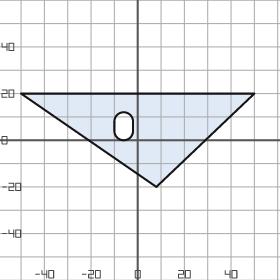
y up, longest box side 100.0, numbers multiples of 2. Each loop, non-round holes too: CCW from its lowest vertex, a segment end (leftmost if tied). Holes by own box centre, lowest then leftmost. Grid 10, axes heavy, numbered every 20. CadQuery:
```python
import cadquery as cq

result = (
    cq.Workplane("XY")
    .moveTo(8.0, -20.0)
    .lineTo(50.0, 20.0)
    .lineTo(-50.0, 20.0)
    .close()
    .moveTo(-10.0, 4.0)
    .threePointArc((-6.0, 0.0), (-2.0, 4.0))
    .lineTo(-2.0, 8.0)
    .threePointArc((-6.0, 12.0), (-10.0, 8.0))
    .close()
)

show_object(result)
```